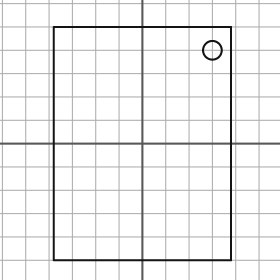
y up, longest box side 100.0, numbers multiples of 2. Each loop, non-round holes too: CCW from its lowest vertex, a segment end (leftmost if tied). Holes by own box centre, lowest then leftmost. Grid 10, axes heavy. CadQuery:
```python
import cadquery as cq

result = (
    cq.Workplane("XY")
    .moveTo(-38.0, -50.0)
    .lineTo(38.0, -50.0)
    .lineTo(38.0, 50.0)
    .lineTo(-38.0, 50.0)
    .close()
    .moveTo(30.0, 40.0)
    .circle(4.0)
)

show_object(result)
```